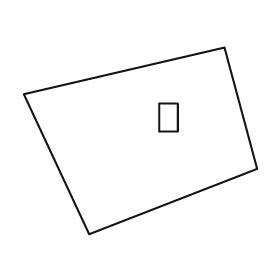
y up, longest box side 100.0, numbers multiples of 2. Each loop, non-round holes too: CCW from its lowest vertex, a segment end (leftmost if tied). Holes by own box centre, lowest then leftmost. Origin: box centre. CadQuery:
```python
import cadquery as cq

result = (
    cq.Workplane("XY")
    .moveTo(-22.0, -40.0)
    .lineTo(50.0, -12.0)
    .lineTo(36.0, 40.0)
    .lineTo(-50.0, 20.0)
    .close()
    .moveTo(8.0, 4.0)
    .lineTo(16.0, 4.0)
    .lineTo(16.0, 16.0)
    .lineTo(8.0, 16.0)
    .close()
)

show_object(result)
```